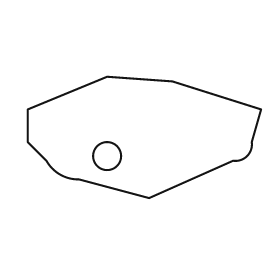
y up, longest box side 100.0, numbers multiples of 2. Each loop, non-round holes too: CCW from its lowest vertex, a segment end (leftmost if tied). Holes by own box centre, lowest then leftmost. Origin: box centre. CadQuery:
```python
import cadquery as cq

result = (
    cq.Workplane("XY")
    .moveTo(2.0, -26.0)
    .lineTo(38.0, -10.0)
    .threePointArc((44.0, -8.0), (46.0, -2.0))
    .lineTo(50.0, 12.0)
    .lineTo(12.0, 24.0)
    .lineTo(-16.0, 26.0)
    .lineTo(-50.0, 12.0)
    .lineTo(-50.0, -2.0)
    .lineTo(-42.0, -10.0)
    .threePointArc((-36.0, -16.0), (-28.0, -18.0))
    .close()
    .moveTo(-16.0, -8.0)
    .circle(6.0)
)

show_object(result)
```